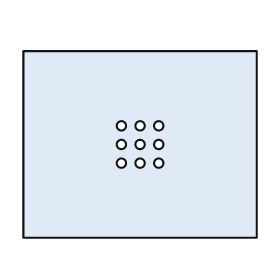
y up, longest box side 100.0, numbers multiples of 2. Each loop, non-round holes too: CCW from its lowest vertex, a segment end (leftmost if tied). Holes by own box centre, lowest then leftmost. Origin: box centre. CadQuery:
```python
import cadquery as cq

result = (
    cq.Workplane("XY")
    .moveTo(-50.0, -40.0)
    .lineTo(50.0, -40.0)
    .lineTo(50.0, 40.0)
    .lineTo(-50.0, 40.0)
    .close()
    .moveTo(-8.0, -8.0)
    .circle(2.0)
    .moveTo(0.0, -8.0)
    .circle(2.0)
    .moveTo(8.0, -8.0)
    .circle(2.0)
    .moveTo(-8.0, 0.0)
    .circle(2.0)
    .moveTo(0.0, 0.0)
    .circle(2.0)
    .moveTo(8.0, 0.0)
    .circle(2.0)
    .moveTo(-8.0, 8.0)
    .circle(2.0)
    .moveTo(0.0, 8.0)
    .circle(2.0)
    .moveTo(8.0, 8.0)
    .circle(2.0)
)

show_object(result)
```